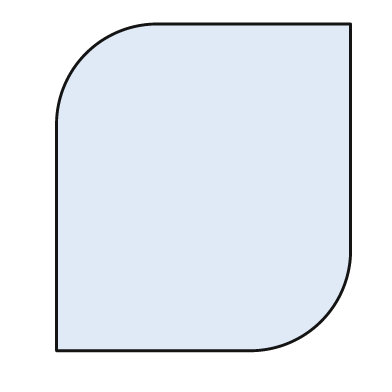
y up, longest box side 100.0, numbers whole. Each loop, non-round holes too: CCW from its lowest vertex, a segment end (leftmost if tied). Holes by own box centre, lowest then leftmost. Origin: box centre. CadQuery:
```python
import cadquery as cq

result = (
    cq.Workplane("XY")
    .moveTo(-45.0, -50.0)
    .lineTo(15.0, -50.0)
    .threePointArc((36.0, -41.0), (45.0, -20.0))
    .lineTo(45.0, 50.0)
    .lineTo(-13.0, 50.0)
    .threePointArc((-36.0, 41.0), (-45.0, 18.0))
    .close()
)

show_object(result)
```